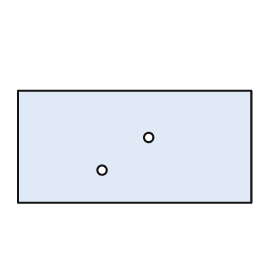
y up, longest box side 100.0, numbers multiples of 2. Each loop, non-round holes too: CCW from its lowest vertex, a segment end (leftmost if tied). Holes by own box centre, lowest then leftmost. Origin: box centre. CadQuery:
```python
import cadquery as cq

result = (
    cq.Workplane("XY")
    .moveTo(-50.0, -24.0)
    .lineTo(50.0, -24.0)
    .lineTo(50.0, 24.0)
    .lineTo(-50.0, 24.0)
    .close()
    .moveTo(-14.0, -10.0)
    .circle(2.0)
    .moveTo(6.0, 4.0)
    .circle(2.0)
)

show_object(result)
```